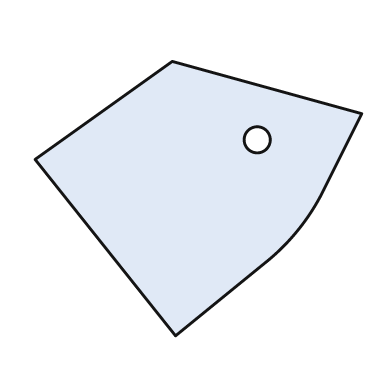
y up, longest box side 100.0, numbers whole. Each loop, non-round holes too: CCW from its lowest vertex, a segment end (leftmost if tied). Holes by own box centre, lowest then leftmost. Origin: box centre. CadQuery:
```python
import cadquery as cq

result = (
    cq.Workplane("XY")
    .moveTo(-7.0, -42.0)
    .lineTo(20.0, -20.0)
    .threePointArc((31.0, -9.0), (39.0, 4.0))
    .lineTo(50.0, 26.0)
    .lineTo(-8.0, 42.0)
    .lineTo(-50.0, 12.0)
    .close()
    .moveTo(18.0, 18.0)
    .circle(4.0)
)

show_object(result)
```